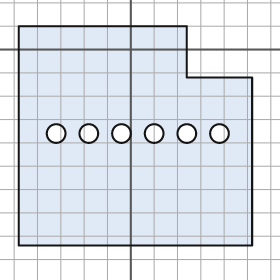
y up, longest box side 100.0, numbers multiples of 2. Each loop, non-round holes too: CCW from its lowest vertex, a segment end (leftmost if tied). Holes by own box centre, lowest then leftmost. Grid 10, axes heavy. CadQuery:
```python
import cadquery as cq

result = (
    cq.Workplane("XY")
    .moveTo(-48.0, -84.0)
    .lineTo(52.0, -84.0)
    .lineTo(52.0, -12.0)
    .lineTo(24.0, -12.0)
    .lineTo(24.0, 10.0)
    .lineTo(-48.0, 10.0)
    .close()
    .moveTo(-32.0, -36.0)
    .circle(4.0)
    .moveTo(-18.0, -36.0)
    .circle(4.0)
    .moveTo(-4.0, -36.0)
    .circle(4.0)
    .moveTo(10.0, -36.0)
    .circle(4.0)
    .moveTo(24.0, -36.0)
    .circle(4.0)
    .moveTo(38.0, -36.0)
    .circle(4.0)
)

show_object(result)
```